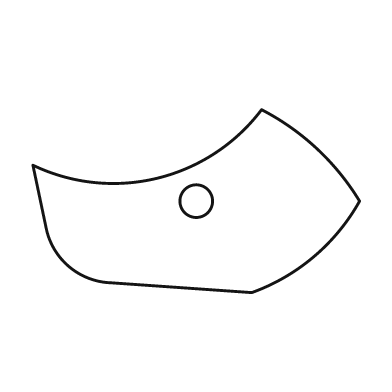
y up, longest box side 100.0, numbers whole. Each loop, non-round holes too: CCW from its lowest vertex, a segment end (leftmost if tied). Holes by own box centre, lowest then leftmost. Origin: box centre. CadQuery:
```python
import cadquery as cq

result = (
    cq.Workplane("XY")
    .moveTo(17.0, -28.0)
    .threePointArc((36.0, -17.0), (50.0, 0.0))
    .threePointArc((37.0, 16.0), (20.0, 28.0))
    .threePointArc((-12.0, 7.0), (-50.0, 11.0))
    .lineTo(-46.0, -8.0)
    .threePointArc((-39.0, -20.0), (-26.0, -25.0))
    .close()
    .moveTo(0.0, 0.0)
    .circle(5.0)
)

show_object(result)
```